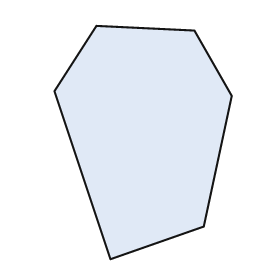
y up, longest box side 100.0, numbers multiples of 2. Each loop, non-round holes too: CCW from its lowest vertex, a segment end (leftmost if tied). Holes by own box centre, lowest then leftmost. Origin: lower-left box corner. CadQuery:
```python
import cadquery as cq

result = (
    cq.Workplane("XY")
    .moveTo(24.0, 0.0)
    .lineTo(64.0, 14.0)
    .lineTo(76.0, 70.0)
    .lineTo(60.0, 98.0)
    .lineTo(18.0, 100.0)
    .lineTo(0.0, 72.0)
    .close()
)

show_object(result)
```